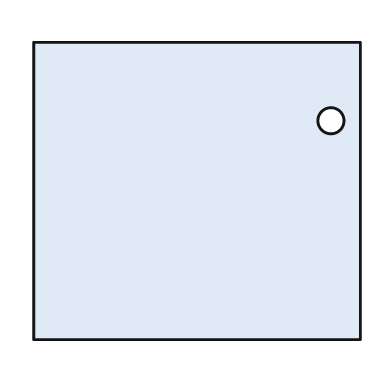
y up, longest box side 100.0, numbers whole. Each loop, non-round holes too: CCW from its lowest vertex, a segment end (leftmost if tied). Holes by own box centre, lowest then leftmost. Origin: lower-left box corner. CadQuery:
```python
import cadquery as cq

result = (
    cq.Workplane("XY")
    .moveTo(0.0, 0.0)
    .lineTo(100.0, 0.0)
    .lineTo(100.0, 91.0)
    .lineTo(0.0, 91.0)
    .close()
    .moveTo(91.0, 67.0)
    .circle(4.0)
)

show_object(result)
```